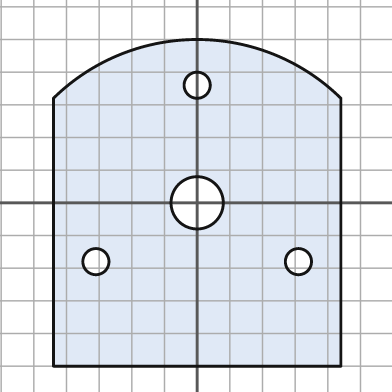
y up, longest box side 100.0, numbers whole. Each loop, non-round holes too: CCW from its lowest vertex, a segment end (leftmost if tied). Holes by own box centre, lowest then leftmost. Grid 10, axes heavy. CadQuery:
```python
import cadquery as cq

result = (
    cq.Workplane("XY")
    .moveTo(-44.0, -50.0)
    .lineTo(44.0, -50.0)
    .lineTo(44.0, 32.0)
    .threePointArc((0.0, 50.0), (-44.0, 32.0))
    .close()
    .moveTo(-31.0, -18.0)
    .circle(4.0)
    .moveTo(31.0, -18.0)
    .circle(4.0)
    .moveTo(0.0, 0.0)
    .circle(8.0)
    .moveTo(0.0, 36.0)
    .circle(4.0)
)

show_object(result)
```